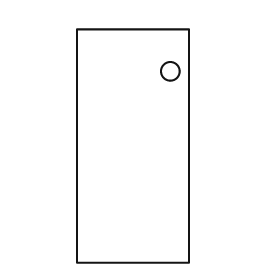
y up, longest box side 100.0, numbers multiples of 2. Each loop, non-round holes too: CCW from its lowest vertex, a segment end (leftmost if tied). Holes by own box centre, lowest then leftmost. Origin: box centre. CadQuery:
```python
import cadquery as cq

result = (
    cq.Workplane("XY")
    .moveTo(-24.0, -50.0)
    .lineTo(24.0, -50.0)
    .lineTo(24.0, 50.0)
    .lineTo(-24.0, 50.0)
    .close()
    .moveTo(16.0, 32.0)
    .circle(4.0)
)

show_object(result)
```